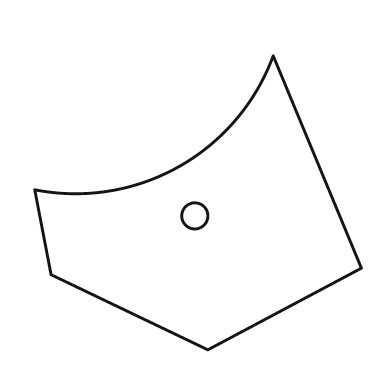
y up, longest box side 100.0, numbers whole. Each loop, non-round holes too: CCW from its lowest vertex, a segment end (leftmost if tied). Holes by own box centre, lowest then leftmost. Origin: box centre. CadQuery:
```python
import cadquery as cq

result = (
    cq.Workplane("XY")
    .moveTo(3.0, -45.0)
    .lineTo(50.0, -20.0)
    .lineTo(23.0, 45.0)
    .threePointArc((-6.0, 11.0), (-50.0, 4.0))
    .lineTo(-45.0, -22.0)
    .close()
    .moveTo(-1.0, -4.0)
    .circle(4.0)
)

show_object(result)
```